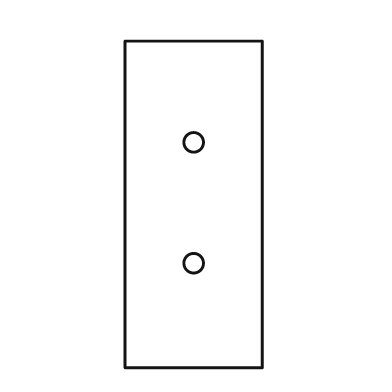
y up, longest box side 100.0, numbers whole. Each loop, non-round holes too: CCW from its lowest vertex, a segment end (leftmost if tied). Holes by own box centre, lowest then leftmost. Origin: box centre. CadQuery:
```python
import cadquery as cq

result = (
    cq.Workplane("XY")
    .moveTo(-21.0, -50.0)
    .lineTo(21.0, -50.0)
    .lineTo(21.0, 50.0)
    .lineTo(-21.0, 50.0)
    .close()
    .moveTo(0.0, -18.0)
    .circle(3.0)
    .moveTo(0.0, 19.0)
    .circle(3.0)
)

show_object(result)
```